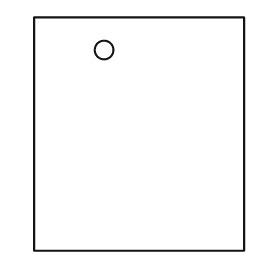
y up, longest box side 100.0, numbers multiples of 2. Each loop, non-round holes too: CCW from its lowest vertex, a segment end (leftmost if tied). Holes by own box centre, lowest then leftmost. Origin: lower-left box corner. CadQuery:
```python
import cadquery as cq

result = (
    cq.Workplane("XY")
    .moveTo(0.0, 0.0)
    .lineTo(90.0, 0.0)
    .lineTo(90.0, 100.0)
    .lineTo(0.0, 100.0)
    .close()
    .moveTo(30.0, 86.0)
    .circle(4.0)
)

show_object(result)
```